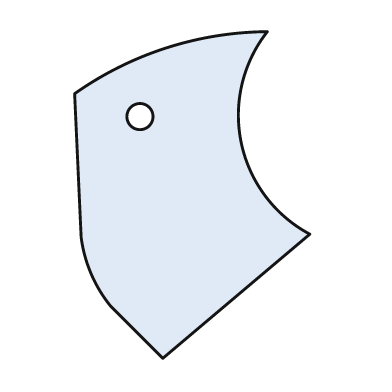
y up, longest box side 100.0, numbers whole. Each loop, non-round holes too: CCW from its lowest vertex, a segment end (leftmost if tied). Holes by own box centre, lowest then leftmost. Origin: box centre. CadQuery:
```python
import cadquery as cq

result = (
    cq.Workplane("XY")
    .moveTo(-9.0, -50.0)
    .lineTo(36.0, -12.0)
    .threePointArc((15.0, 16.0), (23.0, 50.0))
    .threePointArc((-8.0, 45.0), (-36.0, 31.0))
    .lineTo(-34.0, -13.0)
    .threePointArc((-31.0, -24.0), (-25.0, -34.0))
    .close()
    .moveTo(-16.0, 24.0)
    .circle(4.0)
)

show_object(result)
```